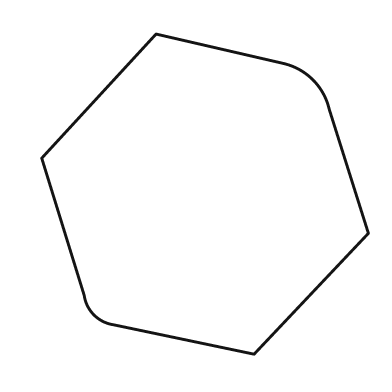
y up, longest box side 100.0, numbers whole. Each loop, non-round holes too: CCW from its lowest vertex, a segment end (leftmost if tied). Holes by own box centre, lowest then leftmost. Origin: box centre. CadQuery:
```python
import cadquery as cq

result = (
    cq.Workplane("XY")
    .moveTo(15.0, -49.0)
    .lineTo(50.0, -12.0)
    .lineTo(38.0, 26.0)
    .threePointArc((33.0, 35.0), (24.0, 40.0))
    .lineTo(-15.0, 49.0)
    .lineTo(-50.0, 11.0)
    .lineTo(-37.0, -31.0)
    .threePointArc((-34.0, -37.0), (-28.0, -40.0))
    .close()
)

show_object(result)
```